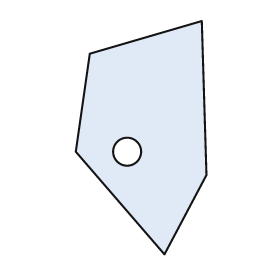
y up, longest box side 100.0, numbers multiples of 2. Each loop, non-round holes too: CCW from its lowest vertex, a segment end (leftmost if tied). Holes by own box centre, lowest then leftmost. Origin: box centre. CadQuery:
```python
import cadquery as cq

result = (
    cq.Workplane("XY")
    .moveTo(10.0, -50.0)
    .lineTo(28.0, -16.0)
    .lineTo(26.0, 50.0)
    .lineTo(-22.0, 36.0)
    .lineTo(-28.0, -6.0)
    .close()
    .moveTo(-6.0, -6.0)
    .circle(6.0)
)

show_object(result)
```